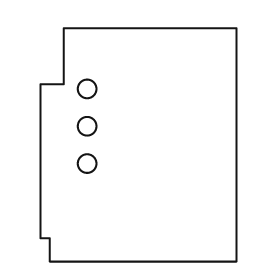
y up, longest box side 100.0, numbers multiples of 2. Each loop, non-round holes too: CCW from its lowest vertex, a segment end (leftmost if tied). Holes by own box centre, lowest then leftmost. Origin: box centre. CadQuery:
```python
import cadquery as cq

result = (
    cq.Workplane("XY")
    .moveTo(-38.0, -50.0)
    .lineTo(42.0, -50.0)
    .lineTo(42.0, 50.0)
    .lineTo(-32.0, 50.0)
    .lineTo(-32.0, 26.0)
    .lineTo(-42.0, 26.0)
    .lineTo(-42.0, -40.0)
    .lineTo(-38.0, -40.0)
    .close()
    .moveTo(-22.0, -8.0)
    .circle(4.0)
    .moveTo(-22.0, 8.0)
    .circle(4.0)
    .moveTo(-22.0, 24.0)
    .circle(4.0)
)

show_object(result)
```